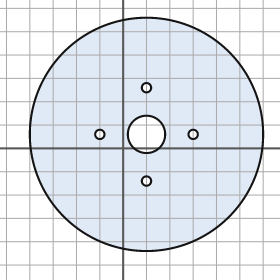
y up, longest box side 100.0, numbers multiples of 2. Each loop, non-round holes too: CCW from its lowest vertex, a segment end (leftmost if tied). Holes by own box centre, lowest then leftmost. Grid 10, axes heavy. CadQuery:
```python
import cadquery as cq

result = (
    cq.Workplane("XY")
    .moveTo(10.0, 6.0)
    .circle(50.0)
    .moveTo(10.0, -14.0)
    .circle(2.0)
    .moveTo(-10.0, 6.0)
    .circle(2.0)
    .moveTo(10.0, 6.0)
    .circle(8.0)
    .moveTo(30.0, 6.0)
    .circle(2.0)
    .moveTo(10.0, 26.0)
    .circle(2.0)
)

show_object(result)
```